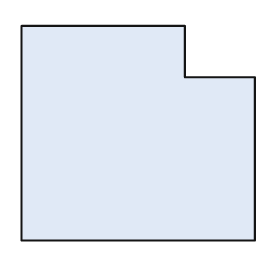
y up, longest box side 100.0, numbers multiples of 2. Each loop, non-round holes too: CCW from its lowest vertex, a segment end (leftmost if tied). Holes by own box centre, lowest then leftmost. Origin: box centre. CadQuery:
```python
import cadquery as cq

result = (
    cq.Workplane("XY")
    .moveTo(-50.0, -46.0)
    .lineTo(50.0, -46.0)
    .lineTo(50.0, 24.0)
    .lineTo(20.0, 24.0)
    .lineTo(20.0, 46.0)
    .lineTo(-50.0, 46.0)
    .close()
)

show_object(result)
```